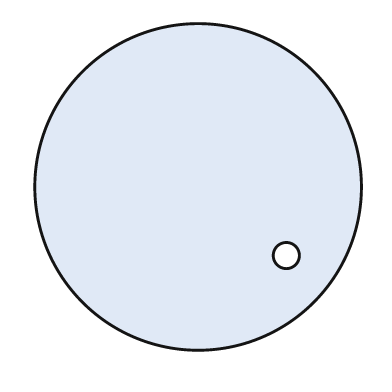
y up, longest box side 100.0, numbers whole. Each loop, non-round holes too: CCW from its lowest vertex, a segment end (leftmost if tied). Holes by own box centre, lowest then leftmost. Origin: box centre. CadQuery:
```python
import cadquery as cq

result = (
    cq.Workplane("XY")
    .moveTo(0.0, 0.0)
    .circle(50.0)
    .moveTo(27.0, -21.0)
    .circle(4.0)
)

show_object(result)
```